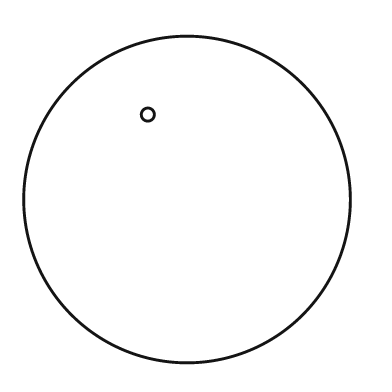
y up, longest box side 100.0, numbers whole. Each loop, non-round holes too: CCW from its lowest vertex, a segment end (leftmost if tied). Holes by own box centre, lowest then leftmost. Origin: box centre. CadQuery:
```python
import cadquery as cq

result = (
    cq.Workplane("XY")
    .moveTo(0.0, 0.0)
    .circle(50.0)
    .moveTo(-12.0, 26.0)
    .circle(2.0)
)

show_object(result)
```